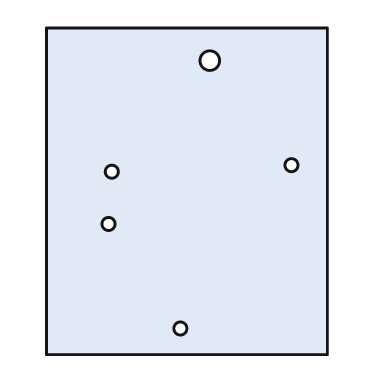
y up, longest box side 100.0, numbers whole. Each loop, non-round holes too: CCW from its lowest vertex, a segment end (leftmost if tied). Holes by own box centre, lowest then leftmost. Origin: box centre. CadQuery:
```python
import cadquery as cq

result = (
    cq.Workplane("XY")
    .moveTo(-43.0, -50.0)
    .lineTo(43.0, -50.0)
    .lineTo(43.0, 50.0)
    .lineTo(-43.0, 50.0)
    .close()
    .moveTo(-2.0, -42.0)
    .circle(2.0)
    .moveTo(-24.0, -10.0)
    .circle(2.0)
    .moveTo(-23.0, 6.0)
    .circle(2.0)
    .moveTo(32.0, 8.0)
    .circle(2.0)
    .moveTo(7.0, 40.0)
    .circle(3.0)
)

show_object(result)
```